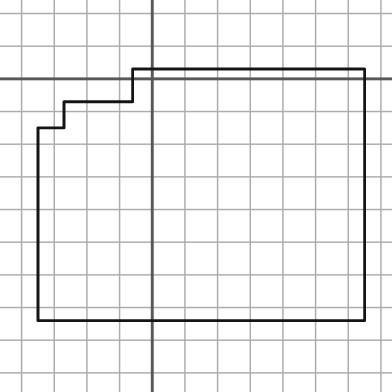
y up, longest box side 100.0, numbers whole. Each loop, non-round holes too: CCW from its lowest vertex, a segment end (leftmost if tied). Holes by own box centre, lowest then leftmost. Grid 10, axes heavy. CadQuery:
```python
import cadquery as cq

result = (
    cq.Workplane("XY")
    .moveTo(-35.0, -74.0)
    .lineTo(65.0, -74.0)
    .lineTo(65.0, 3.0)
    .lineTo(-6.0, 3.0)
    .lineTo(-6.0, -7.0)
    .lineTo(-27.0, -7.0)
    .lineTo(-27.0, -15.0)
    .lineTo(-35.0, -15.0)
    .close()
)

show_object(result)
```